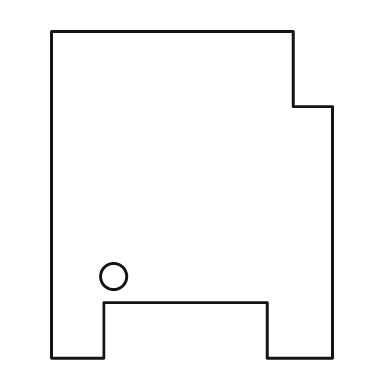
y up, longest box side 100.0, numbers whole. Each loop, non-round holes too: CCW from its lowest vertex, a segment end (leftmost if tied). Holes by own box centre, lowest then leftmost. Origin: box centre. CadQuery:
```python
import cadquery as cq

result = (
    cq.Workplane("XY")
    .moveTo(-43.0, -50.0)
    .lineTo(-27.0, -50.0)
    .lineTo(-27.0, -33.0)
    .lineTo(23.0, -33.0)
    .lineTo(23.0, -50.0)
    .lineTo(43.0, -50.0)
    .lineTo(43.0, 27.0)
    .lineTo(31.0, 27.0)
    .lineTo(31.0, 50.0)
    .lineTo(-43.0, 50.0)
    .close()
    .moveTo(-24.0, -25.0)
    .circle(4.0)
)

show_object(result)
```